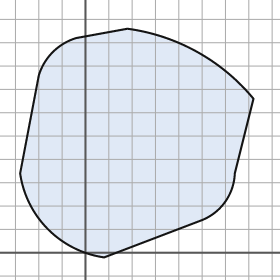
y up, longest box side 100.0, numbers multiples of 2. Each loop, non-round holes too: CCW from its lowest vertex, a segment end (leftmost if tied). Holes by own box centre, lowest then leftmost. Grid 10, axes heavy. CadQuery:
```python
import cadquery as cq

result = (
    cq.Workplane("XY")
    .moveTo(8.0, -2.0)
    .lineTo(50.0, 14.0)
    .threePointArc((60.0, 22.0), (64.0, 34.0))
    .lineTo(72.0, 66.0)
    .threePointArc((48.0, 86.0), (18.0, 96.0))
    .lineTo(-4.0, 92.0)
    .threePointArc((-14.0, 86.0), (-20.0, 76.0))
    .lineTo(-28.0, 34.0)
    .threePointArc((-16.0, 10.0), (8.0, -2.0))
    .close()
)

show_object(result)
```